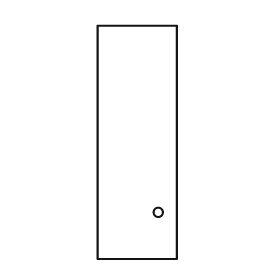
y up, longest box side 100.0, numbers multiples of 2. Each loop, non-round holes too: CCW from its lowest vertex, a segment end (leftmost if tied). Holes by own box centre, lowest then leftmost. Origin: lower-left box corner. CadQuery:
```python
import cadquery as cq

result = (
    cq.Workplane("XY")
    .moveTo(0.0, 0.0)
    .lineTo(34.0, 0.0)
    .lineTo(34.0, 100.0)
    .lineTo(0.0, 100.0)
    .close()
    .moveTo(26.0, 20.0)
    .circle(2.0)
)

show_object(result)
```